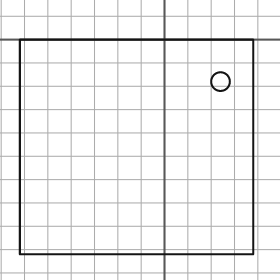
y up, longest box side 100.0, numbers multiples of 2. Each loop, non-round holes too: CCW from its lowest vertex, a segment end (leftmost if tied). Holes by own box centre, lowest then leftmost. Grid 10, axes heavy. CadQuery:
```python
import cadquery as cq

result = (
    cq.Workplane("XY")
    .moveTo(-62.0, -92.0)
    .lineTo(38.0, -92.0)
    .lineTo(38.0, 0.0)
    .lineTo(-62.0, 0.0)
    .close()
    .moveTo(24.0, -18.0)
    .circle(4.0)
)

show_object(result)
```